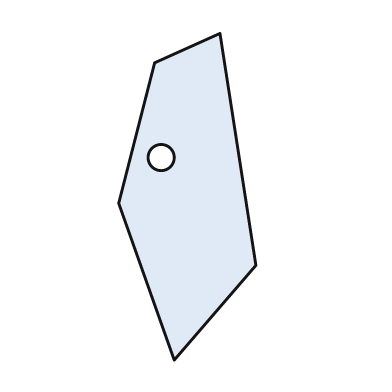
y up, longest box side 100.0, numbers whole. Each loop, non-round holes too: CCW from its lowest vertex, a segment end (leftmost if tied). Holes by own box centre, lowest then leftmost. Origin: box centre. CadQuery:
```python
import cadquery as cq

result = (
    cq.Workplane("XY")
    .moveTo(-4.0, -50.0)
    .lineTo(21.0, -21.0)
    .lineTo(10.0, 50.0)
    .lineTo(-10.0, 41.0)
    .lineTo(-21.0, -2.0)
    .close()
    .moveTo(-8.0, 12.0)
    .circle(4.0)
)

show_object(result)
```